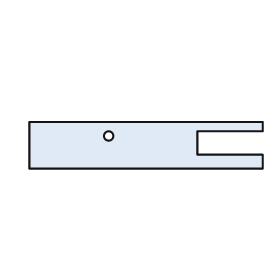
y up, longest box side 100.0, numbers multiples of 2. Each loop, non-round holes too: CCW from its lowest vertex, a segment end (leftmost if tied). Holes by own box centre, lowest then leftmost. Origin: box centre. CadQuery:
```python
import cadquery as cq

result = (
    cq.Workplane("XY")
    .moveTo(-50.0, -10.0)
    .lineTo(50.0, -10.0)
    .lineTo(50.0, -4.0)
    .lineTo(22.0, -4.0)
    .lineTo(22.0, 6.0)
    .lineTo(50.0, 6.0)
    .lineTo(50.0, 10.0)
    .lineTo(-50.0, 10.0)
    .close()
    .moveTo(-16.0, 4.0)
    .circle(2.0)
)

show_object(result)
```